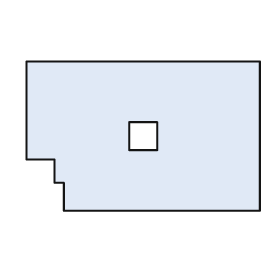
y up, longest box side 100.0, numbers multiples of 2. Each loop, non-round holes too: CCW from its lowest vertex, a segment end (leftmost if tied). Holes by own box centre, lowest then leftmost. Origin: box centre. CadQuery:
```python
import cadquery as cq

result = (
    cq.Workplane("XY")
    .moveTo(-34.0, -32.0)
    .lineTo(50.0, -32.0)
    .lineTo(50.0, 32.0)
    .lineTo(-50.0, 32.0)
    .lineTo(-50.0, -10.0)
    .lineTo(-38.0, -10.0)
    .lineTo(-38.0, -20.0)
    .lineTo(-34.0, -20.0)
    .close()
    .moveTo(-6.0, -6.0)
    .lineTo(6.0, -6.0)
    .lineTo(6.0, 6.0)
    .lineTo(-6.0, 6.0)
    .close()
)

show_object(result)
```